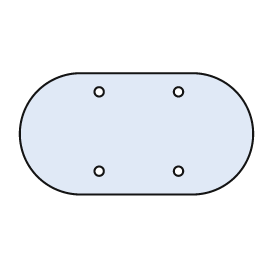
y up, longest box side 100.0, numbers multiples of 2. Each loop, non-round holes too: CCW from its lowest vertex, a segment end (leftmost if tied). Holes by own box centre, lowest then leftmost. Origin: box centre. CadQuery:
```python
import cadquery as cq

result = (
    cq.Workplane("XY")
    .moveTo(-24.0, -26.0)
    .lineTo(24.0, -26.0)
    .threePointArc((50.0, 0.0), (24.0, 26.0))
    .lineTo(-24.0, 26.0)
    .threePointArc((-50.0, 0.0), (-24.0, -26.0))
    .close()
    .moveTo(-16.0, -16.0)
    .circle(2.0)
    .moveTo(18.0, -16.0)
    .circle(2.0)
    .moveTo(-16.0, 18.0)
    .circle(2.0)
    .moveTo(18.0, 18.0)
    .circle(2.0)
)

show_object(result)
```